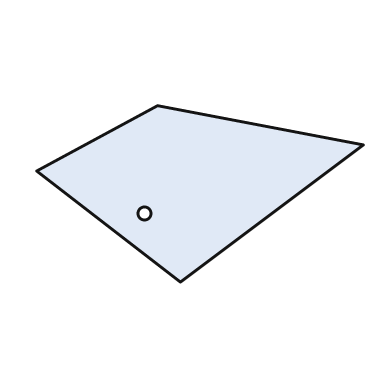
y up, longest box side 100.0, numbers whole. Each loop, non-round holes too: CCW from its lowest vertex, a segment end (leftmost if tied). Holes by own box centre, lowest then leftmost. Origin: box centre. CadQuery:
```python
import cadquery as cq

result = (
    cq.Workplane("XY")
    .moveTo(-6.0, -27.0)
    .lineTo(50.0, 15.0)
    .lineTo(-13.0, 27.0)
    .lineTo(-50.0, 7.0)
    .close()
    .moveTo(-17.0, -6.0)
    .circle(2.0)
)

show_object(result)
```